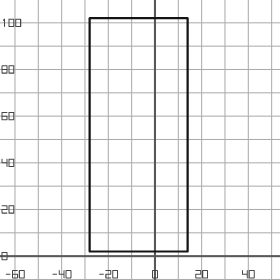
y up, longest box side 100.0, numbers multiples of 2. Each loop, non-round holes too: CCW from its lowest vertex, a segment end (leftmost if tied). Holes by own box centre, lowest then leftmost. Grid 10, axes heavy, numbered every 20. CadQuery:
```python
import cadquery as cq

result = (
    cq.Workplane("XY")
    .moveTo(-28.0, 2.0)
    .lineTo(14.0, 2.0)
    .lineTo(14.0, 102.0)
    .lineTo(-28.0, 102.0)
    .close()
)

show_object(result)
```